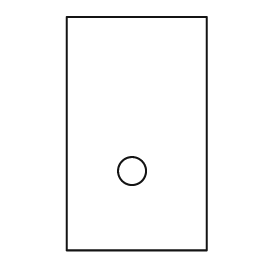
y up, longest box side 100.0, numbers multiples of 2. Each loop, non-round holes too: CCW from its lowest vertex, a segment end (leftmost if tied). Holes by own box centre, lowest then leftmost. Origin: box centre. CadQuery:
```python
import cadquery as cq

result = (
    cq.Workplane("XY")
    .moveTo(-30.0, -50.0)
    .lineTo(30.0, -50.0)
    .lineTo(30.0, 50.0)
    .lineTo(-30.0, 50.0)
    .close()
    .moveTo(-2.0, -16.0)
    .circle(6.0)
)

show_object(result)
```